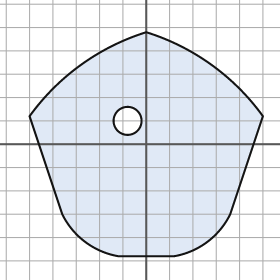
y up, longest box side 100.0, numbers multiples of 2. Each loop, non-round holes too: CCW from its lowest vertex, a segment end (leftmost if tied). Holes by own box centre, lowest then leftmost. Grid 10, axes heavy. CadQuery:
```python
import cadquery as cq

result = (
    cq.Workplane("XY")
    .moveTo(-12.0, -48.0)
    .lineTo(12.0, -48.0)
    .threePointArc((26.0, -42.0), (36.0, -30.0))
    .lineTo(50.0, 12.0)
    .threePointArc((28.0, 34.0), (0.0, 48.0))
    .threePointArc((-28.0, 34.0), (-50.0, 12.0))
    .lineTo(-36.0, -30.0)
    .threePointArc((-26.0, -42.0), (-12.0, -48.0))
    .close()
    .moveTo(-8.0, 10.0)
    .circle(6.0)
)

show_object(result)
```